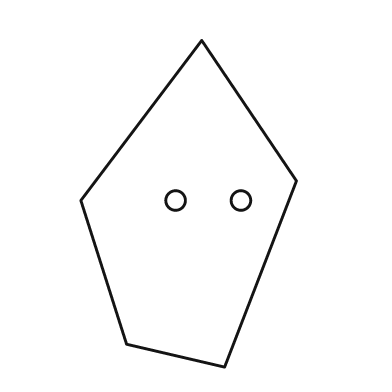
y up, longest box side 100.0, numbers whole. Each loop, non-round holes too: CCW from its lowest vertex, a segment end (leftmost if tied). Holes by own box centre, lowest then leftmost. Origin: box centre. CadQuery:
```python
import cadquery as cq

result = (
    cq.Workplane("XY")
    .moveTo(11.0, -50.0)
    .lineTo(33.0, 7.0)
    .lineTo(4.0, 50.0)
    .lineTo(-33.0, 1.0)
    .lineTo(-19.0, -43.0)
    .close()
    .moveTo(-4.0, 1.0)
    .circle(3.0)
    .moveTo(16.0, 1.0)
    .circle(3.0)
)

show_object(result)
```